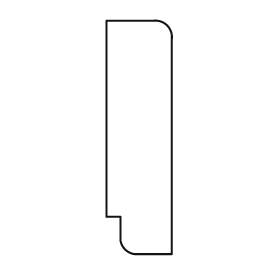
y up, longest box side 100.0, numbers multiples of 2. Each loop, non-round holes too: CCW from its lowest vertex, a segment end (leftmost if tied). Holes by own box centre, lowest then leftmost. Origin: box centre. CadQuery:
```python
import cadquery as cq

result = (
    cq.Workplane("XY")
    .moveTo(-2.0, -50.0)
    .lineTo(14.0, -50.0)
    .lineTo(14.0, 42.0)
    .threePointArc((12.0, 48.0), (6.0, 50.0))
    .lineTo(-14.0, 50.0)
    .lineTo(-14.0, -34.0)
    .lineTo(-8.0, -34.0)
    .lineTo(-8.0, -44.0)
    .threePointArc((-6.0, -48.0), (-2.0, -50.0))
    .close()
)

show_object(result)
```